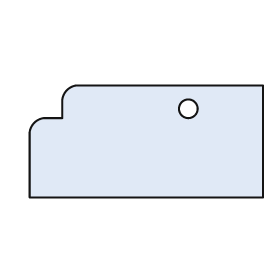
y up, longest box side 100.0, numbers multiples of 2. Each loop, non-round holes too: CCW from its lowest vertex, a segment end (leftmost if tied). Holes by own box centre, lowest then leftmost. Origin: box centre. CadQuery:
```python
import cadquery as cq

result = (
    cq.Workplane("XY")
    .moveTo(-50.0, -24.0)
    .lineTo(50.0, -24.0)
    .lineTo(50.0, 24.0)
    .lineTo(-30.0, 24.0)
    .threePointArc((-34.0, 22.0), (-36.0, 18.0))
    .lineTo(-36.0, 10.0)
    .lineTo(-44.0, 10.0)
    .threePointArc((-48.0, 8.0), (-50.0, 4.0))
    .close()
    .moveTo(18.0, 14.0)
    .circle(4.0)
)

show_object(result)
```